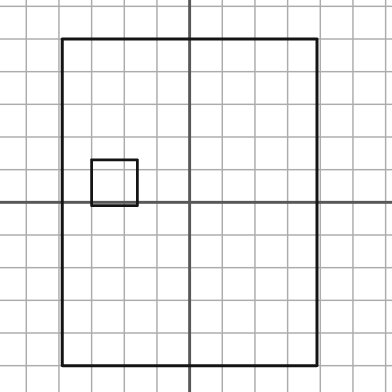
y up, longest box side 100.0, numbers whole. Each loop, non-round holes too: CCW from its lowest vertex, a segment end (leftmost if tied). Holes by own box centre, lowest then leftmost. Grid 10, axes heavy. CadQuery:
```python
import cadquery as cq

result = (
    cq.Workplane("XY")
    .moveTo(-39.0, -50.0)
    .lineTo(39.0, -50.0)
    .lineTo(39.0, 50.0)
    .lineTo(-39.0, 50.0)
    .close()
    .moveTo(-30.0, -1.0)
    .lineTo(-16.0, -1.0)
    .lineTo(-16.0, 13.0)
    .lineTo(-30.0, 13.0)
    .close()
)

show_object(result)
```